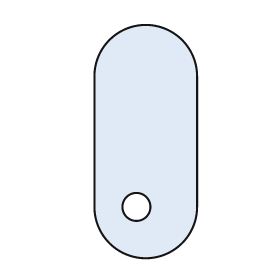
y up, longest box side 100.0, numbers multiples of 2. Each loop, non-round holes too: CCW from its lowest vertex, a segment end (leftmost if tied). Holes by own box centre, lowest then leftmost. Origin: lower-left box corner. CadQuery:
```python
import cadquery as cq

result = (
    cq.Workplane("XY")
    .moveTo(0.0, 22.0)
    .threePointArc((22.0, 0.0), (44.0, 22.0))
    .lineTo(44.0, 78.0)
    .threePointArc((22.0, 100.0), (0.0, 78.0))
    .close()
    .moveTo(18.0, 22.0)
    .circle(6.0)
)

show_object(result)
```